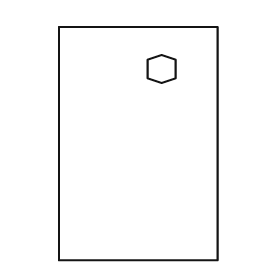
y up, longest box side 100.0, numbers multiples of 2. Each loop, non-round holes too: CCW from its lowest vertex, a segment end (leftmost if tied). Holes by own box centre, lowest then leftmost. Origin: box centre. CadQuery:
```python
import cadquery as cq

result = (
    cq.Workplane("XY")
    .moveTo(-34.0, -50.0)
    .lineTo(34.0, -50.0)
    .lineTo(34.0, 50.0)
    .lineTo(-34.0, 50.0)
    .close()
    .moveTo(10.0, 26.0)
    .lineTo(16.0, 28.0)
    .lineTo(16.0, 36.0)
    .lineTo(10.0, 38.0)
    .lineTo(4.0, 36.0)
    .lineTo(4.0, 28.0)
    .close()
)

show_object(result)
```